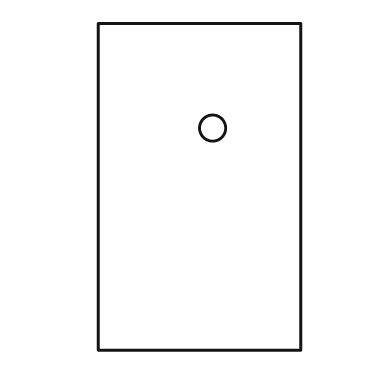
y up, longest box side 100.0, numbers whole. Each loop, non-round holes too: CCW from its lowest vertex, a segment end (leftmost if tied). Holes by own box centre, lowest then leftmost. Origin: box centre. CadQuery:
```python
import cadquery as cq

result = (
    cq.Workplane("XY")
    .moveTo(-31.0, -50.0)
    .lineTo(31.0, -50.0)
    .lineTo(31.0, 50.0)
    .lineTo(-31.0, 50.0)
    .close()
    .moveTo(4.0, 18.0)
    .circle(4.0)
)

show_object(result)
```